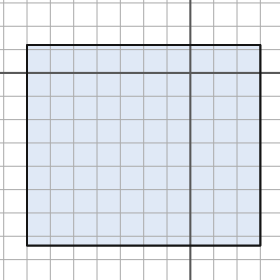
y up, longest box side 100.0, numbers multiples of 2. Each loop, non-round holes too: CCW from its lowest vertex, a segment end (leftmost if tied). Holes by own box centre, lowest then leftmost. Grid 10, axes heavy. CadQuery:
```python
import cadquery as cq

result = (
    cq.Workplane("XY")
    .moveTo(-70.0, -74.0)
    .lineTo(30.0, -74.0)
    .lineTo(30.0, 12.0)
    .lineTo(-70.0, 12.0)
    .close()
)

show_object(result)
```